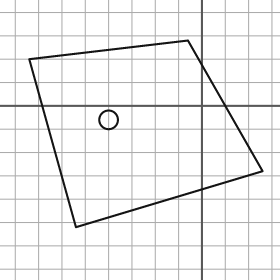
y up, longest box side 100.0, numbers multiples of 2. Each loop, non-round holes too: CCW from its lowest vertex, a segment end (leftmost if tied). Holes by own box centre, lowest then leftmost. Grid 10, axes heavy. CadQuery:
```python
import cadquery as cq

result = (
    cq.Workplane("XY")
    .moveTo(-54.0, -52.0)
    .lineTo(26.0, -28.0)
    .lineTo(-6.0, 28.0)
    .lineTo(-74.0, 20.0)
    .close()
    .moveTo(-40.0, -6.0)
    .circle(4.0)
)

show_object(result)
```